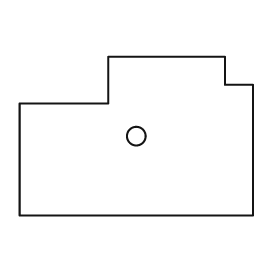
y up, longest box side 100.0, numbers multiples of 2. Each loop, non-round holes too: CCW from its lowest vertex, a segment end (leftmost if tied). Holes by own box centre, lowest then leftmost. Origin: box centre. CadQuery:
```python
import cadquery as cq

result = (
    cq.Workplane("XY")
    .moveTo(-50.0, -34.0)
    .lineTo(50.0, -34.0)
    .lineTo(50.0, 22.0)
    .lineTo(38.0, 22.0)
    .lineTo(38.0, 34.0)
    .lineTo(-12.0, 34.0)
    .lineTo(-12.0, 14.0)
    .lineTo(-50.0, 14.0)
    .close()
    .moveTo(0.0, 0.0)
    .circle(4.0)
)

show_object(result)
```